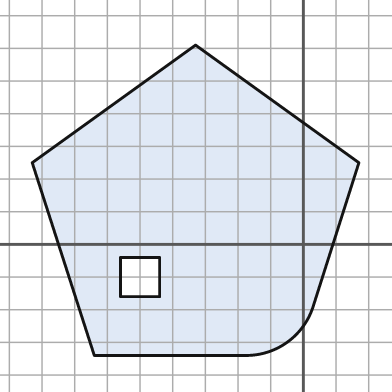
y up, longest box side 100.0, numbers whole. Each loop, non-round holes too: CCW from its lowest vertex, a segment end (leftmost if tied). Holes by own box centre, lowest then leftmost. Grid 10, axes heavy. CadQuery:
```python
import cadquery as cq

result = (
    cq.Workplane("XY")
    .moveTo(-64.0, -34.0)
    .lineTo(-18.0, -34.0)
    .threePointArc((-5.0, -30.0), (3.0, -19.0))
    .lineTo(17.0, 25.0)
    .lineTo(-33.0, 61.0)
    .lineTo(-83.0, 25.0)
    .close()
    .moveTo(-56.0, -16.0)
    .lineTo(-44.0, -16.0)
    .lineTo(-44.0, -4.0)
    .lineTo(-56.0, -4.0)
    .close()
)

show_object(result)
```